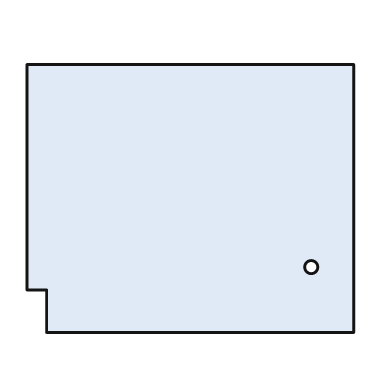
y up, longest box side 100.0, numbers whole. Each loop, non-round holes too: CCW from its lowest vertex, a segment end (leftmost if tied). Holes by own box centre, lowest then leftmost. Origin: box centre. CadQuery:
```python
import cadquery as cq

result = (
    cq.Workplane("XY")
    .moveTo(-44.0, -41.0)
    .lineTo(50.0, -41.0)
    .lineTo(50.0, 41.0)
    .lineTo(-50.0, 41.0)
    .lineTo(-50.0, -28.0)
    .lineTo(-44.0, -28.0)
    .close()
    .moveTo(37.0, -21.0)
    .circle(2.0)
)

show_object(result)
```